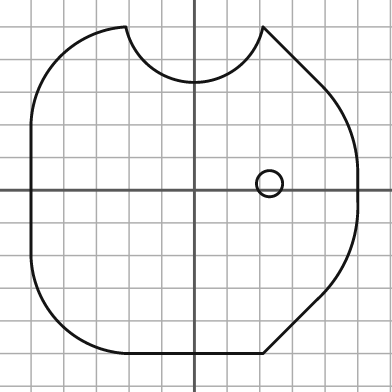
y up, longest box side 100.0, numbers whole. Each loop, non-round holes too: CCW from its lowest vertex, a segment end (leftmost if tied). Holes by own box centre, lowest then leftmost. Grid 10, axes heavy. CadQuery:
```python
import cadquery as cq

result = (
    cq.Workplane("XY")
    .moveTo(-21.0, -50.0)
    .lineTo(21.0, -50.0)
    .lineTo(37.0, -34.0)
    .threePointArc((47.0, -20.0), (50.0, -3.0))
    .lineTo(50.0, 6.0)
    .threePointArc((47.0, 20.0), (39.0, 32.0))
    .lineTo(21.0, 50.0)
    .threePointArc((0.0, 33.0), (-21.0, 50.0))
    .threePointArc((-41.0, 41.0), (-50.0, 21.0))
    .lineTo(-50.0, -21.0)
    .threePointArc((-41.0, -41.0), (-21.0, -50.0))
    .close()
    .moveTo(23.0, 2.0)
    .circle(4.0)
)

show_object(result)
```